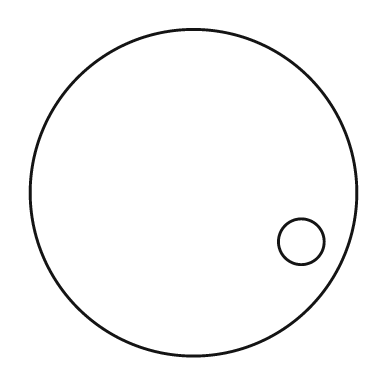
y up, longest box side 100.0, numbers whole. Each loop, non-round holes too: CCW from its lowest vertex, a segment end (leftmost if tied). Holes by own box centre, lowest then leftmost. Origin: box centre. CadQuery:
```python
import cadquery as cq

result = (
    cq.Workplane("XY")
    .moveTo(0.0, 0.0)
    .circle(50.0)
    .moveTo(33.0, -15.0)
    .circle(7.0)
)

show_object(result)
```